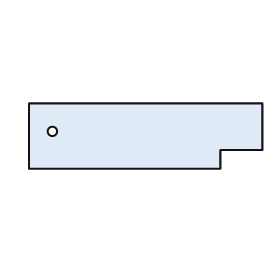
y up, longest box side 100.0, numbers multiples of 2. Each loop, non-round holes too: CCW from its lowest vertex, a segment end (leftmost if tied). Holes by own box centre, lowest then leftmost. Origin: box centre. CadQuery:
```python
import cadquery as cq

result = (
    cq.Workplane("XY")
    .moveTo(-50.0, -14.0)
    .lineTo(32.0, -14.0)
    .lineTo(32.0, -6.0)
    .lineTo(50.0, -6.0)
    .lineTo(50.0, 14.0)
    .lineTo(-50.0, 14.0)
    .close()
    .moveTo(-40.0, 2.0)
    .circle(2.0)
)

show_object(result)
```